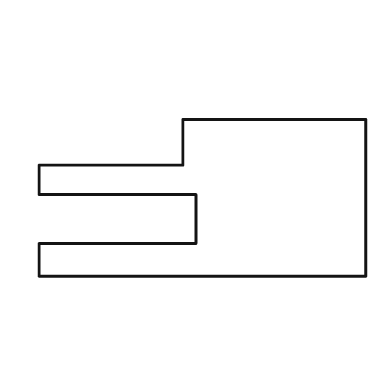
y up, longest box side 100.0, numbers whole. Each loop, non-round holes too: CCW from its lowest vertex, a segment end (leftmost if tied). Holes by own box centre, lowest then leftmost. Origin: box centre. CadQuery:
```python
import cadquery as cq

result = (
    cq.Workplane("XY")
    .moveTo(-50.0, -24.0)
    .lineTo(50.0, -24.0)
    .lineTo(50.0, 24.0)
    .lineTo(-6.0, 24.0)
    .lineTo(-6.0, 10.0)
    .lineTo(-50.0, 10.0)
    .lineTo(-50.0, 1.0)
    .lineTo(-2.0, 1.0)
    .lineTo(-2.0, -14.0)
    .lineTo(-50.0, -14.0)
    .close()
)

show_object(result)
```